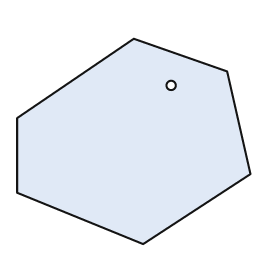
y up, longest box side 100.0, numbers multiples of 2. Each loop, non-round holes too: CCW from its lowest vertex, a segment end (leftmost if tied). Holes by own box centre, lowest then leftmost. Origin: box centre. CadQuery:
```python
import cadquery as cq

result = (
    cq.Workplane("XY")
    .moveTo(4.0, -44.0)
    .lineTo(50.0, -14.0)
    .lineTo(40.0, 30.0)
    .lineTo(0.0, 44.0)
    .lineTo(-50.0, 10.0)
    .lineTo(-50.0, -22.0)
    .close()
    .moveTo(16.0, 24.0)
    .circle(2.0)
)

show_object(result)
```